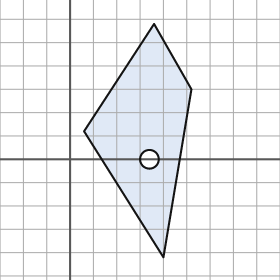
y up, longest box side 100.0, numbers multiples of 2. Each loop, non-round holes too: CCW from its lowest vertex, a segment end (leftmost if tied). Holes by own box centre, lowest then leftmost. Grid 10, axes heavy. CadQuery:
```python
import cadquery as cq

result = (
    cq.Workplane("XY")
    .moveTo(40.0, -42.0)
    .lineTo(52.0, 30.0)
    .lineTo(36.0, 58.0)
    .lineTo(6.0, 12.0)
    .close()
    .moveTo(34.0, 0.0)
    .circle(4.0)
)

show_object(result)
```